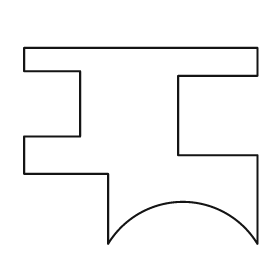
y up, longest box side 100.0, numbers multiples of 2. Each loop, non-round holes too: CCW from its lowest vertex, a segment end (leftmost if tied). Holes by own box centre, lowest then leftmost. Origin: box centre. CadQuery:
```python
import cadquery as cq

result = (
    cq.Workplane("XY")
    .moveTo(-14.0, -42.0)
    .threePointArc((18.0, -24.0), (50.0, -42.0))
    .lineTo(50.0, -4.0)
    .lineTo(16.0, -4.0)
    .lineTo(16.0, 30.0)
    .lineTo(50.0, 30.0)
    .lineTo(50.0, 42.0)
    .lineTo(-50.0, 42.0)
    .lineTo(-50.0, 32.0)
    .lineTo(-26.0, 32.0)
    .lineTo(-26.0, 4.0)
    .lineTo(-50.0, 4.0)
    .lineTo(-50.0, -12.0)
    .lineTo(-14.0, -12.0)
    .close()
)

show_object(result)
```